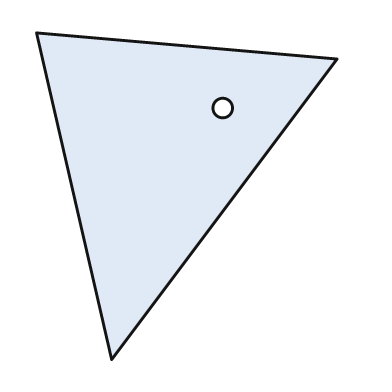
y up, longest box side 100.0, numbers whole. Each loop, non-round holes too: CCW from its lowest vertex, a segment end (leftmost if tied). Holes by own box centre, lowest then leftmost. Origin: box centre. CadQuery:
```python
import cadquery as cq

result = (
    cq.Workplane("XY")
    .moveTo(-23.0, -50.0)
    .lineTo(46.0, 42.0)
    .lineTo(-46.0, 50.0)
    .close()
    .moveTo(11.0, 27.0)
    .circle(3.0)
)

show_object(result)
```